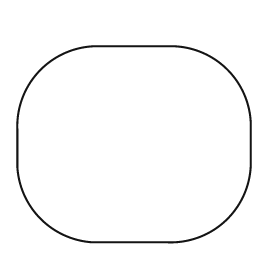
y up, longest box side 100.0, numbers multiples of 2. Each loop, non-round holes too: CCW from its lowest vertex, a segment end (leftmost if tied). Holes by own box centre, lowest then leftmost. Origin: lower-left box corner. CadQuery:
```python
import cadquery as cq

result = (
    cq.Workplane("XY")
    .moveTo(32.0, 0.0)
    .lineTo(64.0, 0.0)
    .threePointArc((90.0, 10.0), (100.0, 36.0))
    .lineTo(100.0, 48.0)
    .threePointArc((90.0, 74.0), (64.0, 84.0))
    .lineTo(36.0, 84.0)
    .threePointArc((10.0, 74.0), (0.0, 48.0))
    .lineTo(0.0, 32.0)
    .threePointArc((10.0, 10.0), (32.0, 0.0))
    .close()
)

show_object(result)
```